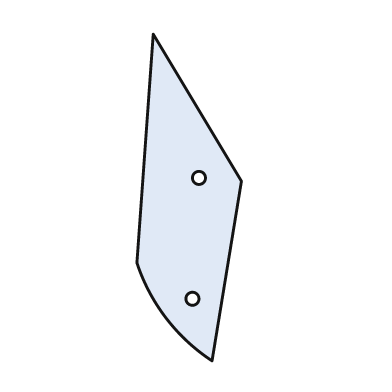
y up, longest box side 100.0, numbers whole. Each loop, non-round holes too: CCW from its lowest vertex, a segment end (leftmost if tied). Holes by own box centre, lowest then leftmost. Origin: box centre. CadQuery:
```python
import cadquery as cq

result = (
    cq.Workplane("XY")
    .moveTo(7.0, -50.0)
    .lineTo(16.0, 5.0)
    .lineTo(-11.0, 50.0)
    .lineTo(-16.0, -20.0)
    .threePointArc((-7.0, -37.0), (7.0, -50.0))
    .close()
    .moveTo(1.0, -31.0)
    .circle(2.0)
    .moveTo(3.0, 6.0)
    .circle(2.0)
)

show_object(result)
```